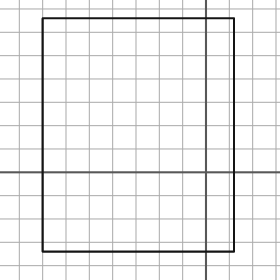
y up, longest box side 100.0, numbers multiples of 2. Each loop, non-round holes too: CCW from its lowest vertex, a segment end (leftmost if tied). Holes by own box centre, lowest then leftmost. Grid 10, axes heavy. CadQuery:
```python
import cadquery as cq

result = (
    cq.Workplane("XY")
    .moveTo(-70.0, -34.0)
    .lineTo(12.0, -34.0)
    .lineTo(12.0, 66.0)
    .lineTo(-70.0, 66.0)
    .close()
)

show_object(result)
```